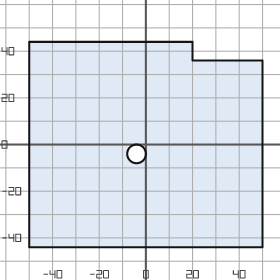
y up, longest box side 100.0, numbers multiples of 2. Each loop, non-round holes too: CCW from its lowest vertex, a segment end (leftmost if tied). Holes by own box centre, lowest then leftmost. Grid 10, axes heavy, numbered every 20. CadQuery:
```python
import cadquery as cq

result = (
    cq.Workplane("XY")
    .moveTo(-50.0, -44.0)
    .lineTo(50.0, -44.0)
    .lineTo(50.0, 36.0)
    .lineTo(20.0, 36.0)
    .lineTo(20.0, 44.0)
    .lineTo(-50.0, 44.0)
    .close()
    .moveTo(-4.0, -4.0)
    .circle(4.0)
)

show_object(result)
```